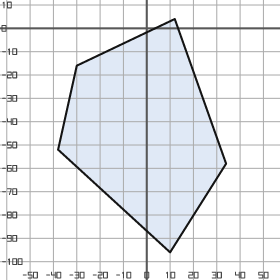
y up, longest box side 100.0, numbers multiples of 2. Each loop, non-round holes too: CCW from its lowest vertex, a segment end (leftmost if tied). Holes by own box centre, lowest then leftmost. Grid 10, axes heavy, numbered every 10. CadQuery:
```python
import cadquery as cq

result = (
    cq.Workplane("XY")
    .moveTo(10.0, -96.0)
    .lineTo(34.0, -58.0)
    .lineTo(12.0, 4.0)
    .lineTo(-30.0, -16.0)
    .lineTo(-38.0, -52.0)
    .close()
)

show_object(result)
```